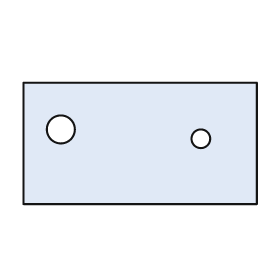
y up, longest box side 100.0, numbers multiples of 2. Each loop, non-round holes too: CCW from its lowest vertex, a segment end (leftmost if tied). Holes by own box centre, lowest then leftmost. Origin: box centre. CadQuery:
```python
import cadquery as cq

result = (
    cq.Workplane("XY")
    .moveTo(-50.0, -26.0)
    .lineTo(50.0, -26.0)
    .lineTo(50.0, 26.0)
    .lineTo(-50.0, 26.0)
    .close()
    .moveTo(26.0, 2.0)
    .circle(4.0)
    .moveTo(-34.0, 6.0)
    .circle(6.0)
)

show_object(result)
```